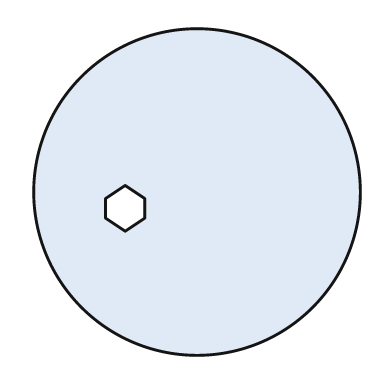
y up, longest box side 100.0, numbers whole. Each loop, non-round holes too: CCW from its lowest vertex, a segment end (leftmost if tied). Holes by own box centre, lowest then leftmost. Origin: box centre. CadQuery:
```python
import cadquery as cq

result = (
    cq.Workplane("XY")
    .moveTo(0.0, 0.0)
    .circle(50.0)
    .moveTo(-22.0, -12.0)
    .lineTo(-16.0, -8.0)
    .lineTo(-16.0, -2.0)
    .lineTo(-22.0, 2.0)
    .lineTo(-28.0, -2.0)
    .lineTo(-28.0, -8.0)
    .close()
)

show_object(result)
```